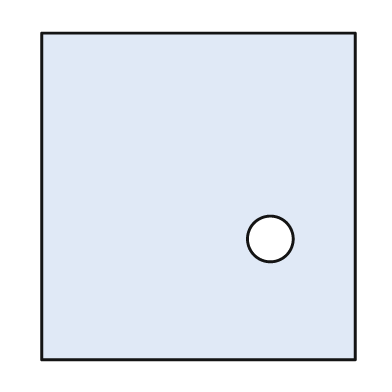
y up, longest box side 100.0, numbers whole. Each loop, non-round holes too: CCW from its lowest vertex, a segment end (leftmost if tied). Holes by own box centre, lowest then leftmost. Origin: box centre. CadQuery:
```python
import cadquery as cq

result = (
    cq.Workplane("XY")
    .moveTo(-48.0, -50.0)
    .lineTo(48.0, -50.0)
    .lineTo(48.0, 50.0)
    .lineTo(-48.0, 50.0)
    .close()
    .moveTo(22.0, -13.0)
    .circle(7.0)
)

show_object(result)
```